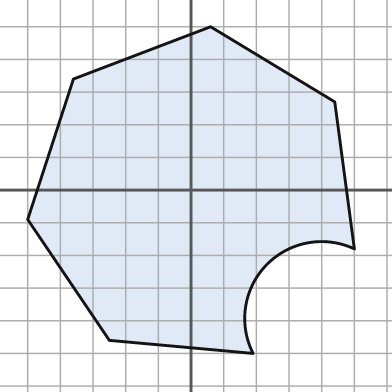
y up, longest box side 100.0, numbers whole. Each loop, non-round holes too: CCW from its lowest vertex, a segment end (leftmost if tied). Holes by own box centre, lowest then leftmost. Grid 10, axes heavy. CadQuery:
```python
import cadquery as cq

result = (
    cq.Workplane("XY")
    .moveTo(19.0, -50.0)
    .threePointArc((23.0, -23.0), (50.0, -18.0))
    .lineTo(44.0, 27.0)
    .lineTo(6.0, 50.0)
    .lineTo(-36.0, 34.0)
    .lineTo(-50.0, -9.0)
    .lineTo(-25.0, -46.0)
    .close()
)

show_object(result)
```